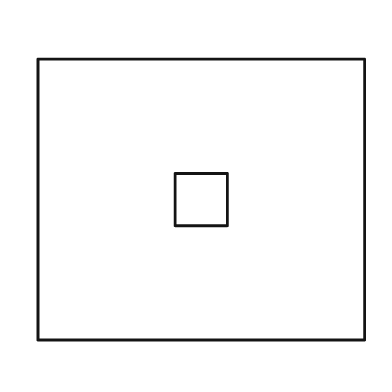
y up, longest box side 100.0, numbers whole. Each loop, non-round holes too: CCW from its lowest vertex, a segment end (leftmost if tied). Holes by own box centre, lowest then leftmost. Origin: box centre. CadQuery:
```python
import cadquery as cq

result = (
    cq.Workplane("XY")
    .moveTo(-50.0, -43.0)
    .lineTo(50.0, -43.0)
    .lineTo(50.0, 43.0)
    .lineTo(-50.0, 43.0)
    .close()
    .moveTo(-8.0, -8.0)
    .lineTo(8.0, -8.0)
    .lineTo(8.0, 8.0)
    .lineTo(-8.0, 8.0)
    .close()
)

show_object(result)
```